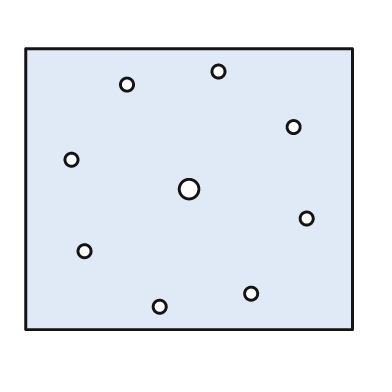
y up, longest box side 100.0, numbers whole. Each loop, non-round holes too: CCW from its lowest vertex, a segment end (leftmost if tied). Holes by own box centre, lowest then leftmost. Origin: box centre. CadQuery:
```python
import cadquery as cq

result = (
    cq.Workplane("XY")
    .moveTo(-50.0, -43.0)
    .lineTo(50.0, -43.0)
    .lineTo(50.0, 43.0)
    .lineTo(-50.0, 43.0)
    .close()
    .moveTo(-9.0, -36.0)
    .circle(2.0)
    .moveTo(19.0, -32.0)
    .circle(2.0)
    .moveTo(-32.0, -19.0)
    .circle(2.0)
    .moveTo(36.0, -9.0)
    .circle(2.0)
    .moveTo(0.0, 0.0)
    .circle(3.0)
    .moveTo(-36.0, 9.0)
    .circle(2.0)
    .moveTo(32.0, 19.0)
    .circle(2.0)
    .moveTo(-19.0, 32.0)
    .circle(2.0)
    .moveTo(9.0, 36.0)
    .circle(2.0)
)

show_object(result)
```